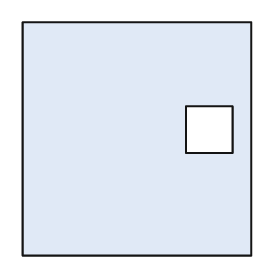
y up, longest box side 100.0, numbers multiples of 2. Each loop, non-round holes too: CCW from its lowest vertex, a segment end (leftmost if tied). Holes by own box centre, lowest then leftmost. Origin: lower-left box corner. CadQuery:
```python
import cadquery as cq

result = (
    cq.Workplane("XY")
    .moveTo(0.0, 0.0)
    .lineTo(98.0, 0.0)
    .lineTo(98.0, 100.0)
    .lineTo(0.0, 100.0)
    .close()
    .moveTo(70.0, 44.0)
    .lineTo(90.0, 44.0)
    .lineTo(90.0, 64.0)
    .lineTo(70.0, 64.0)
    .close()
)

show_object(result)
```